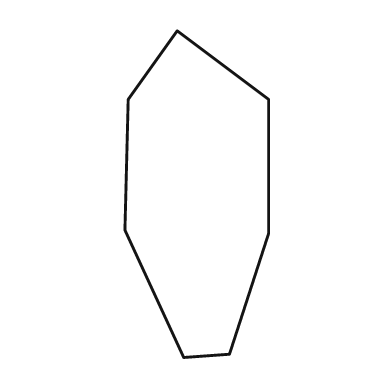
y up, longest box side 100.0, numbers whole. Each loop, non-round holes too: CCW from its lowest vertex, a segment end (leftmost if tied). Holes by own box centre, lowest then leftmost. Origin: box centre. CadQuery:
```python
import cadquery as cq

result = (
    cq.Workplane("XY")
    .moveTo(-4.0, -50.0)
    .lineTo(10.0, -49.0)
    .lineTo(22.0, -12.0)
    .lineTo(22.0, 29.0)
    .lineTo(-6.0, 50.0)
    .lineTo(-21.0, 29.0)
    .lineTo(-22.0, -11.0)
    .close()
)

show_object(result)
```